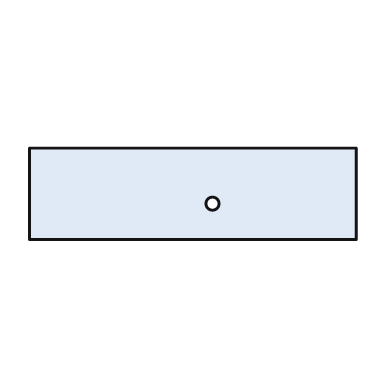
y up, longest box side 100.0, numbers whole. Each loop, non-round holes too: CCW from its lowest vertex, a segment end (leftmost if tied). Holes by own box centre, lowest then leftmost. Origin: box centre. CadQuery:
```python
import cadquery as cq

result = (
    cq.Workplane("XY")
    .moveTo(-50.0, -14.0)
    .lineTo(50.0, -14.0)
    .lineTo(50.0, 14.0)
    .lineTo(-50.0, 14.0)
    .close()
    .moveTo(6.0, -3.0)
    .circle(2.0)
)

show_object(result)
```